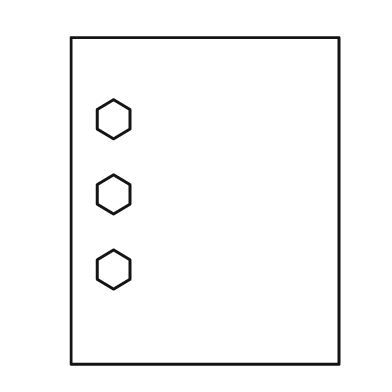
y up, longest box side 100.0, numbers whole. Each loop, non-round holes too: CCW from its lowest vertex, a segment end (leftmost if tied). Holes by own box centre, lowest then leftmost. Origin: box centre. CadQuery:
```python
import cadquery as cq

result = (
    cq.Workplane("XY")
    .moveTo(-41.0, -50.0)
    .lineTo(41.0, -50.0)
    .lineTo(41.0, 50.0)
    .lineTo(-41.0, 50.0)
    .close()
    .moveTo(-28.0, -27.0)
    .lineTo(-23.0, -24.0)
    .lineTo(-23.0, -18.0)
    .lineTo(-28.0, -15.0)
    .lineTo(-33.0, -18.0)
    .lineTo(-33.0, -24.0)
    .close()
    .moveTo(-28.0, -4.0)
    .lineTo(-23.0, -1.0)
    .lineTo(-23.0, 5.0)
    .lineTo(-28.0, 8.0)
    .lineTo(-33.0, 5.0)
    .lineTo(-33.0, -1.0)
    .close()
    .moveTo(-28.0, 19.0)
    .lineTo(-23.0, 22.0)
    .lineTo(-23.0, 28.0)
    .lineTo(-28.0, 31.0)
    .lineTo(-33.0, 28.0)
    .lineTo(-33.0, 22.0)
    .close()
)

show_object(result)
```